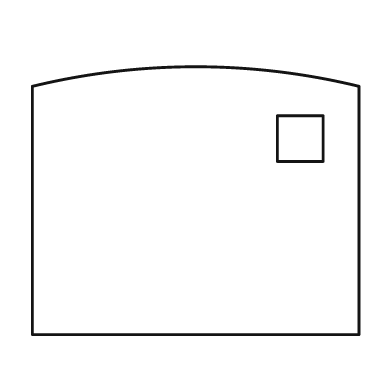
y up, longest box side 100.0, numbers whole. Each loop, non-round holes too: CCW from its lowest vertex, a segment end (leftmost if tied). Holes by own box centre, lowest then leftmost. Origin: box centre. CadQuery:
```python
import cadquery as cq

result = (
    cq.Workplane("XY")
    .moveTo(-50.0, -41.0)
    .lineTo(50.0, -41.0)
    .lineTo(50.0, 35.0)
    .threePointArc((0.0, 41.0), (-50.0, 35.0))
    .close()
    .moveTo(25.0, 12.0)
    .lineTo(39.0, 12.0)
    .lineTo(39.0, 26.0)
    .lineTo(25.0, 26.0)
    .close()
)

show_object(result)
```